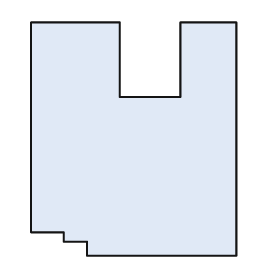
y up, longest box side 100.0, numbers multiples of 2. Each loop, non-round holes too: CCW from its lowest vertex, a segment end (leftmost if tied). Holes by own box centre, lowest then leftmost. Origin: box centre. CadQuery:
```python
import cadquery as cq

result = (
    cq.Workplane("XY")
    .moveTo(-20.0, -50.0)
    .lineTo(44.0, -50.0)
    .lineTo(44.0, 50.0)
    .lineTo(20.0, 50.0)
    .lineTo(20.0, 18.0)
    .lineTo(-6.0, 18.0)
    .lineTo(-6.0, 50.0)
    .lineTo(-44.0, 50.0)
    .lineTo(-44.0, -40.0)
    .lineTo(-30.0, -40.0)
    .lineTo(-30.0, -44.0)
    .lineTo(-20.0, -44.0)
    .close()
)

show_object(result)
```